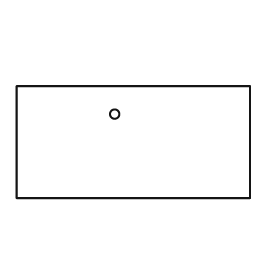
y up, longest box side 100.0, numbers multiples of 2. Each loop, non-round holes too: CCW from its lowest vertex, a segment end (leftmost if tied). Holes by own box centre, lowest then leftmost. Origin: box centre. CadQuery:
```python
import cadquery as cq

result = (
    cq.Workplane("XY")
    .moveTo(-50.0, -24.0)
    .lineTo(50.0, -24.0)
    .lineTo(50.0, 24.0)
    .lineTo(-50.0, 24.0)
    .close()
    .moveTo(-8.0, 12.0)
    .circle(2.0)
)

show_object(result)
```